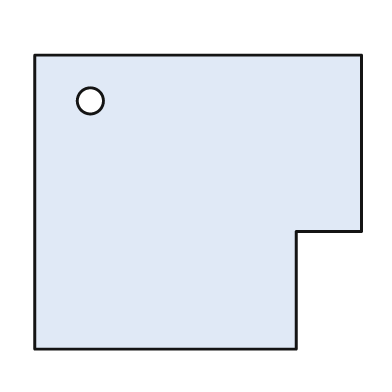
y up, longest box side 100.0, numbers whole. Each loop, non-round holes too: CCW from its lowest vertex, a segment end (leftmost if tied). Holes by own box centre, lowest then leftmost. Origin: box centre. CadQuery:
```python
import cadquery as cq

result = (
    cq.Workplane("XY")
    .moveTo(-50.0, -45.0)
    .lineTo(30.0, -45.0)
    .lineTo(30.0, -9.0)
    .lineTo(50.0, -9.0)
    .lineTo(50.0, 45.0)
    .lineTo(-50.0, 45.0)
    .close()
    .moveTo(-33.0, 31.0)
    .circle(4.0)
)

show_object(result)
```